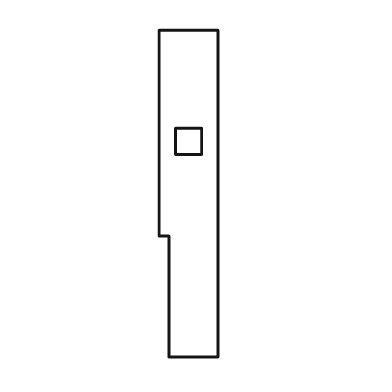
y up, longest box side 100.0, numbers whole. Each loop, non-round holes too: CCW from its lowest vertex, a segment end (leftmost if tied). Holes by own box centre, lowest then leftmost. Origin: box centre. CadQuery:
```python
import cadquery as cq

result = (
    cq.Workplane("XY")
    .moveTo(-6.0, -50.0)
    .lineTo(9.0, -50.0)
    .lineTo(9.0, 50.0)
    .lineTo(-9.0, 50.0)
    .lineTo(-9.0, -13.0)
    .lineTo(-6.0, -13.0)
    .close()
    .moveTo(-4.0, 12.0)
    .lineTo(4.0, 12.0)
    .lineTo(4.0, 20.0)
    .lineTo(-4.0, 20.0)
    .close()
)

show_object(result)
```